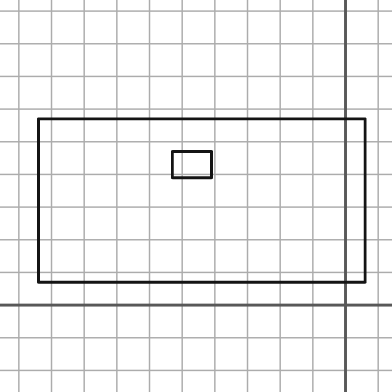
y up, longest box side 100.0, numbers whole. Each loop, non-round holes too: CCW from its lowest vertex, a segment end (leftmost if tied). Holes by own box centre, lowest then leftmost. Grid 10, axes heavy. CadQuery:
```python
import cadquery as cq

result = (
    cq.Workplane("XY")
    .moveTo(-94.0, 7.0)
    .lineTo(6.0, 7.0)
    .lineTo(6.0, 57.0)
    .lineTo(-94.0, 57.0)
    .close()
    .moveTo(-53.0, 39.0)
    .lineTo(-41.0, 39.0)
    .lineTo(-41.0, 47.0)
    .lineTo(-53.0, 47.0)
    .close()
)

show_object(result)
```